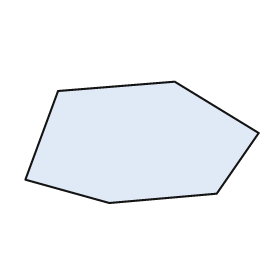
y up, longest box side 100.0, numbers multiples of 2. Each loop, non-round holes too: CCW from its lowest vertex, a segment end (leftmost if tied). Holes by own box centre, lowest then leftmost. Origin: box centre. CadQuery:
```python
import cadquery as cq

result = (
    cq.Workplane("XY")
    .moveTo(-14.0, -26.0)
    .lineTo(32.0, -22.0)
    .lineTo(50.0, 4.0)
    .lineTo(14.0, 26.0)
    .lineTo(-36.0, 22.0)
    .lineTo(-50.0, -16.0)
    .close()
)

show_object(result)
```